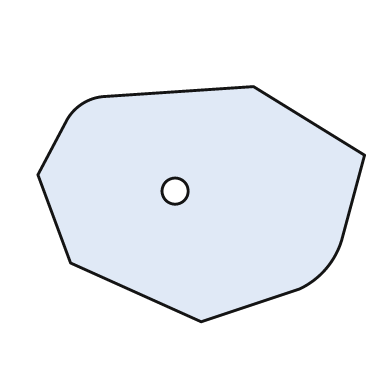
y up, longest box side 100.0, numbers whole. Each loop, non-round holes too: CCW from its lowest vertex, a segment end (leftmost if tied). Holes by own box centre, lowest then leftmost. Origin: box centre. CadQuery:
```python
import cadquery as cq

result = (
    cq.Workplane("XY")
    .moveTo(0.0, -36.0)
    .lineTo(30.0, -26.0)
    .threePointArc((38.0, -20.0), (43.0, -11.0))
    .lineTo(50.0, 15.0)
    .lineTo(16.0, 36.0)
    .lineTo(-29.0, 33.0)
    .threePointArc((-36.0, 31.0), (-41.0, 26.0))
    .lineTo(-50.0, 9.0)
    .lineTo(-40.0, -18.0)
    .close()
    .moveTo(-8.0, 4.0)
    .circle(4.0)
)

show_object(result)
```